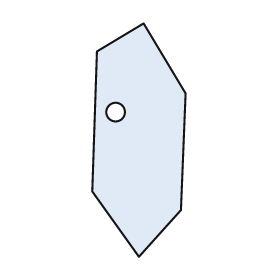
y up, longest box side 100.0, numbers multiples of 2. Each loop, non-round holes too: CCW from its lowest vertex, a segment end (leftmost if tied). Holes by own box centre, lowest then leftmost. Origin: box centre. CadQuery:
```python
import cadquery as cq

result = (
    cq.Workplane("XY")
    .moveTo(0.0, -50.0)
    .lineTo(18.0, -30.0)
    .lineTo(20.0, 20.0)
    .lineTo(2.0, 50.0)
    .lineTo(-18.0, 38.0)
    .lineTo(-20.0, -22.0)
    .close()
    .moveTo(-10.0, 12.0)
    .circle(4.0)
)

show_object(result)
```